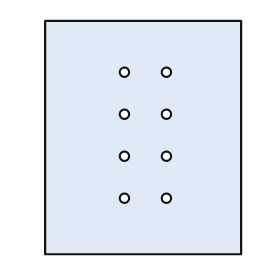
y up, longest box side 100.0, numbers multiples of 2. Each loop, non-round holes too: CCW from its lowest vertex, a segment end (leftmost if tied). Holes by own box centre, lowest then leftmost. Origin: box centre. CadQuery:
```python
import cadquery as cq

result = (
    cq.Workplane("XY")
    .moveTo(-42.0, -50.0)
    .lineTo(42.0, -50.0)
    .lineTo(42.0, 50.0)
    .lineTo(-42.0, 50.0)
    .close()
    .moveTo(-8.0, -26.0)
    .circle(2.0)
    .moveTo(10.0, -26.0)
    .circle(2.0)
    .moveTo(-8.0, -8.0)
    .circle(2.0)
    .moveTo(10.0, -8.0)
    .circle(2.0)
    .moveTo(-8.0, 10.0)
    .circle(2.0)
    .moveTo(10.0, 10.0)
    .circle(2.0)
    .moveTo(-8.0, 28.0)
    .circle(2.0)
    .moveTo(10.0, 28.0)
    .circle(2.0)
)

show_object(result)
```